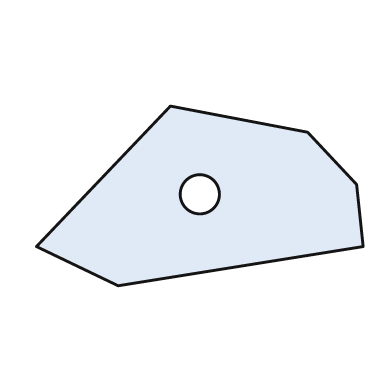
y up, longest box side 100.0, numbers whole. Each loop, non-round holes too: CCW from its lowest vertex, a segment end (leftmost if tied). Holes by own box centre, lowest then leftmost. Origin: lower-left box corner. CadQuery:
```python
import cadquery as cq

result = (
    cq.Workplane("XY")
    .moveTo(25.0, 0.0)
    .lineTo(100.0, 12.0)
    .lineTo(98.0, 31.0)
    .lineTo(83.0, 47.0)
    .lineTo(41.0, 55.0)
    .lineTo(0.0, 12.0)
    .close()
    .moveTo(50.0, 28.0)
    .circle(6.0)
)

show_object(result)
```